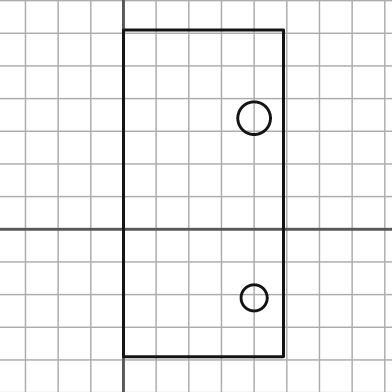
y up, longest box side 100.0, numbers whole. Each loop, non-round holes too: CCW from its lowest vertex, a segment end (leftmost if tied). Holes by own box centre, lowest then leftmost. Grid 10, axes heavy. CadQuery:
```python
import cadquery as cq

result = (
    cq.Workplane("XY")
    .moveTo(0.0, -39.0)
    .lineTo(49.0, -39.0)
    .lineTo(49.0, 61.0)
    .lineTo(0.0, 61.0)
    .close()
    .moveTo(40.0, -21.0)
    .circle(4.0)
    .moveTo(40.0, 34.0)
    .circle(5.0)
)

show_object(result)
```